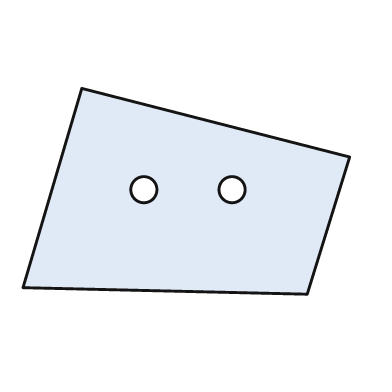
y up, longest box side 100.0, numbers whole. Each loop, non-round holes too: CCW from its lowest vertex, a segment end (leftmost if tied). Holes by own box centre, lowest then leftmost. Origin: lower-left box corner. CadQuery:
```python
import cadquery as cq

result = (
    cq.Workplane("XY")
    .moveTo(87.0, 0.0)
    .lineTo(100.0, 42.0)
    .lineTo(18.0, 63.0)
    .lineTo(0.0, 2.0)
    .close()
    .moveTo(37.0, 32.0)
    .circle(4.0)
    .moveTo(64.0, 32.0)
    .circle(4.0)
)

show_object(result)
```